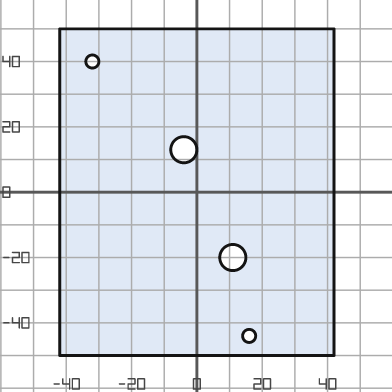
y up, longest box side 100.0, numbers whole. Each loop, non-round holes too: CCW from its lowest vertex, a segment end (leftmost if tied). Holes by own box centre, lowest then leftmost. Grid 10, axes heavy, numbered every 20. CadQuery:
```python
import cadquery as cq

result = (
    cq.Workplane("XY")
    .moveTo(-42.0, -50.0)
    .lineTo(42.0, -50.0)
    .lineTo(42.0, 50.0)
    .lineTo(-42.0, 50.0)
    .close()
    .moveTo(16.0, -44.0)
    .circle(2.0)
    .moveTo(11.0, -20.0)
    .circle(4.0)
    .moveTo(-4.0, 13.0)
    .circle(4.0)
    .moveTo(-32.0, 40.0)
    .circle(2.0)
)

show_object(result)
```